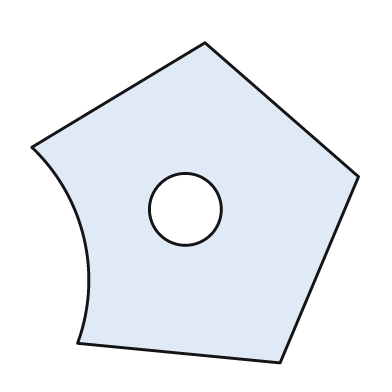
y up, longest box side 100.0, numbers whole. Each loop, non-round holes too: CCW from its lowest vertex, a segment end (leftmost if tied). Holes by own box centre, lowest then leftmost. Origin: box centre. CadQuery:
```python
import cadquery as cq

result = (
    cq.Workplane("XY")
    .moveTo(26.0, -49.0)
    .lineTo(50.0, 8.0)
    .lineTo(3.0, 49.0)
    .lineTo(-50.0, 17.0)
    .threePointArc((-34.0, -11.0), (-36.0, -43.0))
    .close()
    .moveTo(-3.0, -2.0)
    .circle(11.0)
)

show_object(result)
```